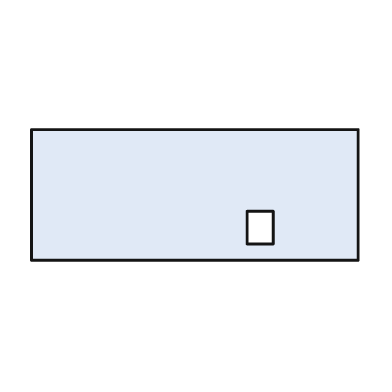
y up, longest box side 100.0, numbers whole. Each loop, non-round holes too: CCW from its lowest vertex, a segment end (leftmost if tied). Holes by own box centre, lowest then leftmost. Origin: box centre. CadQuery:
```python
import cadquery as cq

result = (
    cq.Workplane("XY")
    .moveTo(-50.0, -20.0)
    .lineTo(50.0, -20.0)
    .lineTo(50.0, 20.0)
    .lineTo(-50.0, 20.0)
    .close()
    .moveTo(16.0, -15.0)
    .lineTo(24.0, -15.0)
    .lineTo(24.0, -5.0)
    .lineTo(16.0, -5.0)
    .close()
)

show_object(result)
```